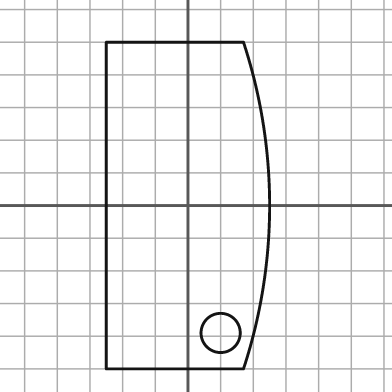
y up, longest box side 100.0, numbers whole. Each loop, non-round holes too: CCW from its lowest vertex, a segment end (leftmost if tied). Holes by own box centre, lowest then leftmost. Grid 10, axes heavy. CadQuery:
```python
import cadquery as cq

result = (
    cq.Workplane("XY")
    .moveTo(-25.0, -50.0)
    .lineTo(17.0, -50.0)
    .threePointArc((25.0, 0.0), (17.0, 50.0))
    .lineTo(-25.0, 50.0)
    .close()
    .moveTo(10.0, -39.0)
    .circle(6.0)
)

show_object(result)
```